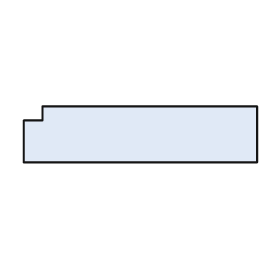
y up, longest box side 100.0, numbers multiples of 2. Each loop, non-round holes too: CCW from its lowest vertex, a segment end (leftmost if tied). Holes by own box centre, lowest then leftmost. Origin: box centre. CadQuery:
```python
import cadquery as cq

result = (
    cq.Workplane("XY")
    .moveTo(-50.0, -12.0)
    .lineTo(50.0, -12.0)
    .lineTo(50.0, 12.0)
    .lineTo(-42.0, 12.0)
    .lineTo(-42.0, 6.0)
    .lineTo(-50.0, 6.0)
    .close()
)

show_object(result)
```